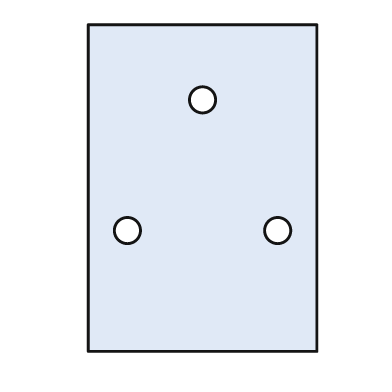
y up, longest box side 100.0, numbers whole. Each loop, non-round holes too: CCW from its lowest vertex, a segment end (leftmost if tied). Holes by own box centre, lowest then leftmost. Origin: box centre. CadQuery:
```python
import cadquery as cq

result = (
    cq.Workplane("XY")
    .moveTo(-35.0, -50.0)
    .lineTo(35.0, -50.0)
    .lineTo(35.0, 50.0)
    .lineTo(-35.0, 50.0)
    .close()
    .moveTo(-23.0, -13.0)
    .circle(4.0)
    .moveTo(23.0, -13.0)
    .circle(4.0)
    .moveTo(0.0, 27.0)
    .circle(4.0)
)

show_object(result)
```